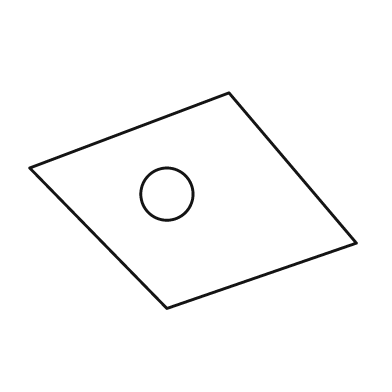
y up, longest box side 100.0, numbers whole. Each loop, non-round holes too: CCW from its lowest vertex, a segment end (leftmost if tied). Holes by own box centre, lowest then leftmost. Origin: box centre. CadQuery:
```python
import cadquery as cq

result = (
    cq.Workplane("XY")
    .moveTo(-8.0, -33.0)
    .lineTo(50.0, -13.0)
    .lineTo(11.0, 33.0)
    .lineTo(-50.0, 10.0)
    .close()
    .moveTo(-8.0, 2.0)
    .circle(8.0)
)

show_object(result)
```